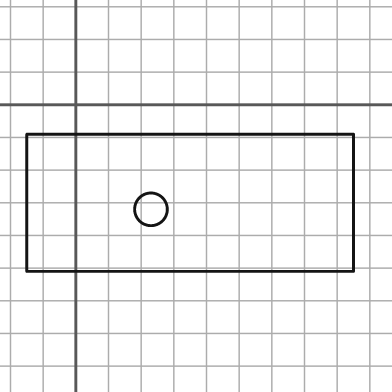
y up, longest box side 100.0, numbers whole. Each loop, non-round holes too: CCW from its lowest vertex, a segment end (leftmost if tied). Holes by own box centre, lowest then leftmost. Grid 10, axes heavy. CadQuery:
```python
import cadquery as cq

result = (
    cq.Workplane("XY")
    .moveTo(-15.0, -51.0)
    .lineTo(85.0, -51.0)
    .lineTo(85.0, -9.0)
    .lineTo(-15.0, -9.0)
    .close()
    .moveTo(23.0, -32.0)
    .circle(5.0)
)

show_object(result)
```